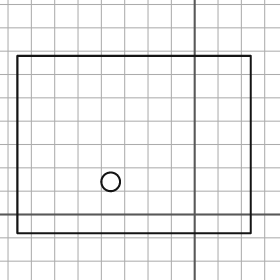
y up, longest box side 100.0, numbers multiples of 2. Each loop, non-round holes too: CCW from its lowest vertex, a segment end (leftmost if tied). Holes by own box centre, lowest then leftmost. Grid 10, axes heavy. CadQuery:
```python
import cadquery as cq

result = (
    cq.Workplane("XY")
    .moveTo(-76.0, -8.0)
    .lineTo(24.0, -8.0)
    .lineTo(24.0, 68.0)
    .lineTo(-76.0, 68.0)
    .close()
    .moveTo(-36.0, 14.0)
    .circle(4.0)
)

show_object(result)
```